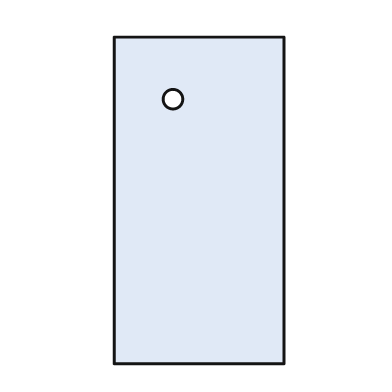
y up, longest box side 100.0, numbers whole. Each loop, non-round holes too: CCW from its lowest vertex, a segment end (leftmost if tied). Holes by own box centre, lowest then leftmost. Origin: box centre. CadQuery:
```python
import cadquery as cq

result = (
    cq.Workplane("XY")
    .moveTo(-26.0, -50.0)
    .lineTo(26.0, -50.0)
    .lineTo(26.0, 50.0)
    .lineTo(-26.0, 50.0)
    .close()
    .moveTo(-8.0, 31.0)
    .circle(3.0)
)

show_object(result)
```